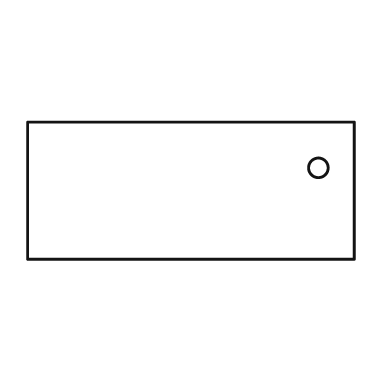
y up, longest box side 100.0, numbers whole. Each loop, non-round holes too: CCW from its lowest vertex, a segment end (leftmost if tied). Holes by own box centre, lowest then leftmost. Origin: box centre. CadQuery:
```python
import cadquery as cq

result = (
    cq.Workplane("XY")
    .moveTo(-50.0, -21.0)
    .lineTo(50.0, -21.0)
    .lineTo(50.0, 21.0)
    .lineTo(-50.0, 21.0)
    .close()
    .moveTo(39.0, 7.0)
    .circle(3.0)
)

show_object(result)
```